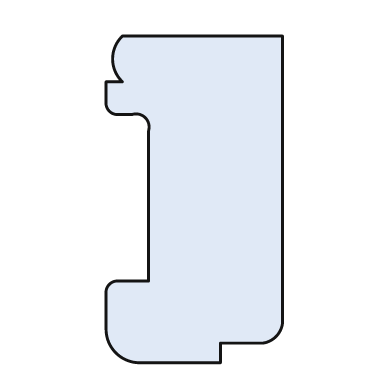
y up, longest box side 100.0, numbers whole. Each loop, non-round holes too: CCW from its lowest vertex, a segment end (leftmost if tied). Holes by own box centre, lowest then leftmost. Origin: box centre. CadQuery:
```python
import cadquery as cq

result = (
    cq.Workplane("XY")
    .moveTo(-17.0, -50.0)
    .lineTo(8.0, -50.0)
    .lineTo(8.0, -44.0)
    .lineTo(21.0, -44.0)
    .threePointArc((25.0, -42.0), (27.0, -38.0))
    .lineTo(27.0, 50.0)
    .lineTo(-22.0, 50.0)
    .threePointArc((-25.0, 43.0), (-22.0, 36.0))
    .lineTo(-27.0, 36.0)
    .lineTo(-27.0, 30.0)
    .threePointArc((-26.0, 27.0), (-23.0, 26.0))
    .lineTo(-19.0, 26.0)
    .threePointArc((-15.0, 25.0), (-14.0, 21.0))
    .lineTo(-14.0, -25.0)
    .lineTo(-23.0, -25.0)
    .threePointArc((-26.0, -26.0), (-27.0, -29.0))
    .lineTo(-27.0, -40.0)
    .threePointArc((-24.0, -47.0), (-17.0, -50.0))
    .close()
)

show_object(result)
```